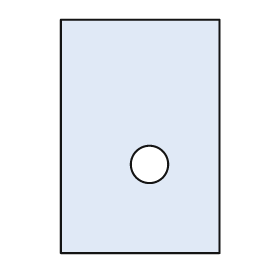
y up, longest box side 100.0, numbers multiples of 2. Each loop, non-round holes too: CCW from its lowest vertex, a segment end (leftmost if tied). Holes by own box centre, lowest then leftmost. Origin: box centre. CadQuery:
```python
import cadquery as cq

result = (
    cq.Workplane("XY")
    .moveTo(-34.0, -50.0)
    .lineTo(34.0, -50.0)
    .lineTo(34.0, 50.0)
    .lineTo(-34.0, 50.0)
    .close()
    .moveTo(4.0, -12.0)
    .circle(8.0)
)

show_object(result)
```